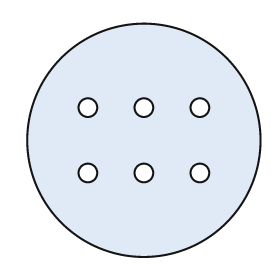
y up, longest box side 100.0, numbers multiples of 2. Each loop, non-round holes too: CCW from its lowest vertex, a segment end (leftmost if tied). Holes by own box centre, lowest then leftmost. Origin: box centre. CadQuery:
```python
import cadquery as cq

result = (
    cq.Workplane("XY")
    .moveTo(0.0, 0.0)
    .circle(50.0)
    .moveTo(-24.0, -14.0)
    .circle(4.0)
    .moveTo(0.0, -14.0)
    .circle(4.0)
    .moveTo(24.0, -14.0)
    .circle(4.0)
    .moveTo(-24.0, 14.0)
    .circle(4.0)
    .moveTo(0.0, 14.0)
    .circle(4.0)
    .moveTo(24.0, 14.0)
    .circle(4.0)
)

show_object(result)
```